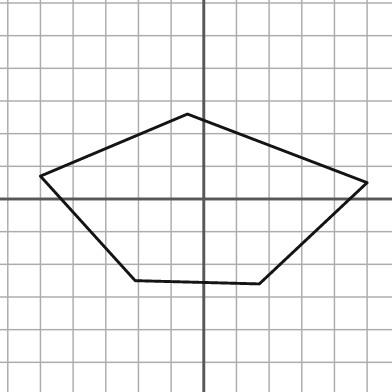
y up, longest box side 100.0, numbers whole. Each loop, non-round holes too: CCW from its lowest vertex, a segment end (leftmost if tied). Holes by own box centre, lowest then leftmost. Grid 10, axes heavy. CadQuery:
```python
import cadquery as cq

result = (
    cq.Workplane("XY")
    .moveTo(17.0, -26.0)
    .lineTo(50.0, 5.0)
    .lineTo(-5.0, 26.0)
    .lineTo(-50.0, 7.0)
    .lineTo(-21.0, -25.0)
    .close()
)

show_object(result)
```